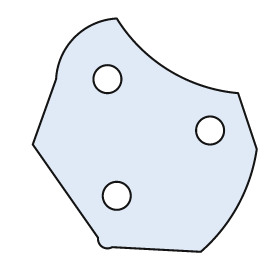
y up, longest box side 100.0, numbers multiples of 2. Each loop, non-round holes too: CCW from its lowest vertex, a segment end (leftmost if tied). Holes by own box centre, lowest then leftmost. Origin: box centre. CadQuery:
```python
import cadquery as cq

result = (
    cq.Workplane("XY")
    .moveTo(24.0, -50.0)
    .threePointArc((40.0, -30.0), (48.0, -6.0))
    .lineTo(40.0, 18.0)
    .threePointArc((10.0, 28.0), (-12.0, 50.0))
    .threePointArc((-30.0, 42.0), (-38.0, 24.0))
    .lineTo(-48.0, -4.0)
    .lineTo(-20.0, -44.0)
    .threePointArc((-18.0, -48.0), (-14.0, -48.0))
    .close()
    .moveTo(-12.0, -26.0)
    .circle(6.0)
    .moveTo(28.0, 2.0)
    .circle(6.0)
    .moveTo(-16.0, 24.0)
    .circle(6.0)
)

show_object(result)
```